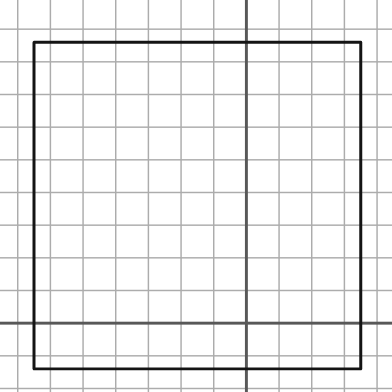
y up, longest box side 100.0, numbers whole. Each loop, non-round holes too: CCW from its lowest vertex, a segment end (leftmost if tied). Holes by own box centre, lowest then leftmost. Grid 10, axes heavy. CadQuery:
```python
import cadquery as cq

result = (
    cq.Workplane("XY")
    .moveTo(-65.0, -14.0)
    .lineTo(35.0, -14.0)
    .lineTo(35.0, 86.0)
    .lineTo(-65.0, 86.0)
    .close()
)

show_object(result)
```